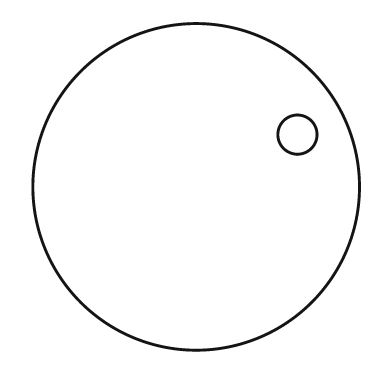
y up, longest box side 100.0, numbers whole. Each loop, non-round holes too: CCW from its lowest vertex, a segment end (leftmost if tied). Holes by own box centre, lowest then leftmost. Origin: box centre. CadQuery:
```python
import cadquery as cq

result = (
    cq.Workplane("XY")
    .moveTo(0.0, 0.0)
    .circle(50.0)
    .moveTo(31.0, 16.0)
    .circle(6.0)
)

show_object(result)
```